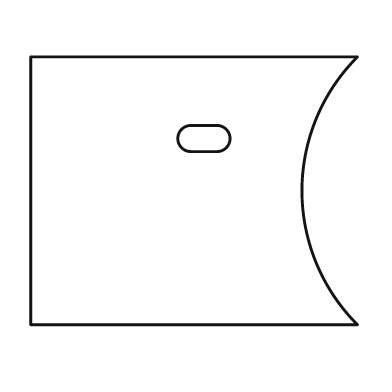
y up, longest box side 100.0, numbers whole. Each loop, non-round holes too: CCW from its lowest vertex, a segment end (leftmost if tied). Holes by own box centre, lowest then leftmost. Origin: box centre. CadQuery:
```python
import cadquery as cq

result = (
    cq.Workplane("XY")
    .moveTo(-50.0, -41.0)
    .lineTo(50.0, -41.0)
    .threePointArc((33.0, 0.0), (50.0, 41.0))
    .lineTo(-50.0, 41.0)
    .close()
    .moveTo(-1.0, 12.0)
    .lineTo(7.0, 12.0)
    .threePointArc((11.0, 16.0), (7.0, 20.0))
    .lineTo(-1.0, 20.0)
    .threePointArc((-5.0, 16.0), (-1.0, 12.0))
    .close()
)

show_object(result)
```